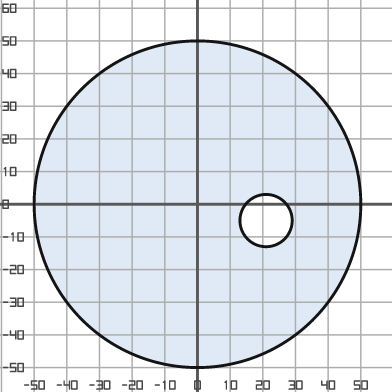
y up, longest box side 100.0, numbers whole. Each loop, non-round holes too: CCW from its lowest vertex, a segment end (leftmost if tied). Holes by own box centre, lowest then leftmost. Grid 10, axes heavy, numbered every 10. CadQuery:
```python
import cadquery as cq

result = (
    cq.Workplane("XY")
    .moveTo(0.0, 0.0)
    .circle(50.0)
    .moveTo(21.0, -5.0)
    .circle(8.0)
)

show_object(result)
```